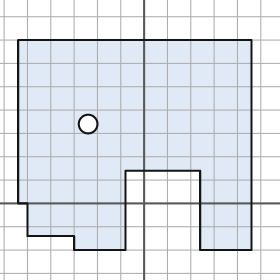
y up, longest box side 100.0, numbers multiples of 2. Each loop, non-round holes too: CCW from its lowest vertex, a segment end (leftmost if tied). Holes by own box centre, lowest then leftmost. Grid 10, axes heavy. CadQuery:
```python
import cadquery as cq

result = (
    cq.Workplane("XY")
    .moveTo(-30.0, -20.0)
    .lineTo(-8.0, -20.0)
    .lineTo(-8.0, 14.0)
    .lineTo(24.0, 14.0)
    .lineTo(24.0, -20.0)
    .lineTo(46.0, -20.0)
    .lineTo(46.0, 70.0)
    .lineTo(-54.0, 70.0)
    .lineTo(-54.0, 0.0)
    .lineTo(-50.0, 0.0)
    .lineTo(-50.0, -14.0)
    .lineTo(-30.0, -14.0)
    .close()
    .moveTo(-24.0, 34.0)
    .circle(4.0)
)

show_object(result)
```